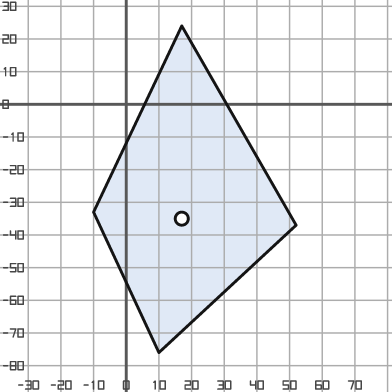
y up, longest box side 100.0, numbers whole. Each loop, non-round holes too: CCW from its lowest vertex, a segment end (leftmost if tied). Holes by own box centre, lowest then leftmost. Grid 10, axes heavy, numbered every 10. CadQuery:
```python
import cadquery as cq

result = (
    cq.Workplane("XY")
    .moveTo(10.0, -76.0)
    .lineTo(52.0, -37.0)
    .lineTo(17.0, 24.0)
    .lineTo(-10.0, -33.0)
    .close()
    .moveTo(17.0, -35.0)
    .circle(2.0)
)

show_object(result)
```